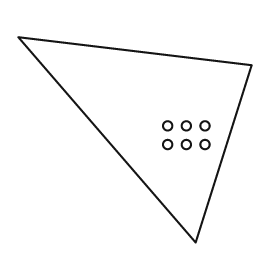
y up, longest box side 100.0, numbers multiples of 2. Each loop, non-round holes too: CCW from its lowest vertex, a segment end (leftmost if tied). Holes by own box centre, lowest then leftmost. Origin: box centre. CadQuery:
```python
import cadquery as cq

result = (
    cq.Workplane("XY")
    .moveTo(26.0, -44.0)
    .lineTo(50.0, 32.0)
    .lineTo(-50.0, 44.0)
    .close()
    .moveTo(14.0, -2.0)
    .circle(2.0)
    .moveTo(22.0, -2.0)
    .circle(2.0)
    .moveTo(30.0, -2.0)
    .circle(2.0)
    .moveTo(14.0, 6.0)
    .circle(2.0)
    .moveTo(22.0, 6.0)
    .circle(2.0)
    .moveTo(30.0, 6.0)
    .circle(2.0)
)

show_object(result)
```